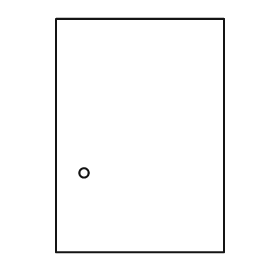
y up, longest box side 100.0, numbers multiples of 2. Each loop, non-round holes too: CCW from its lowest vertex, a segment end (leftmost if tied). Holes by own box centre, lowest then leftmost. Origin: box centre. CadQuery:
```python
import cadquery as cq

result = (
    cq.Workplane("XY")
    .moveTo(-36.0, -50.0)
    .lineTo(36.0, -50.0)
    .lineTo(36.0, 50.0)
    .lineTo(-36.0, 50.0)
    .close()
    .moveTo(-24.0, -16.0)
    .circle(2.0)
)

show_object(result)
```